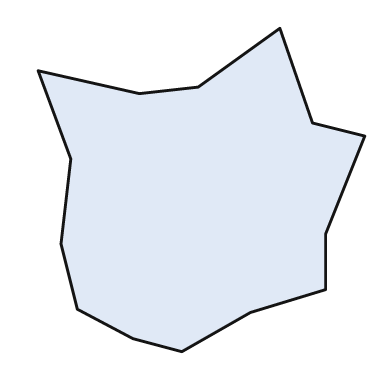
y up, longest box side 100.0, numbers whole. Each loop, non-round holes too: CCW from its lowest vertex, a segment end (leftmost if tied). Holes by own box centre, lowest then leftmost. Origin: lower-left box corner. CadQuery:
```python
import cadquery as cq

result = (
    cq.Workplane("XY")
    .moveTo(44.0, 0.0)
    .lineTo(65.0, 12.0)
    .lineTo(88.0, 19.0)
    .lineTo(88.0, 36.0)
    .lineTo(100.0, 66.0)
    .lineTo(84.0, 70.0)
    .lineTo(74.0, 99.0)
    .lineTo(49.0, 81.0)
    .lineTo(31.0, 79.0)
    .lineTo(0.0, 86.0)
    .lineTo(10.0, 59.0)
    .lineTo(7.0, 33.0)
    .lineTo(12.0, 13.0)
    .lineTo(29.0, 4.0)
    .close()
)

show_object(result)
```